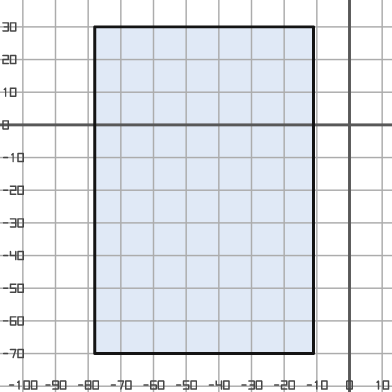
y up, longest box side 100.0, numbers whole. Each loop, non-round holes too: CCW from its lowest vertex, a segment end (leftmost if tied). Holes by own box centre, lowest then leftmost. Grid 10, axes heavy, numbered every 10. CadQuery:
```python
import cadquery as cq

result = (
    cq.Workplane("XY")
    .moveTo(-78.0, -70.0)
    .lineTo(-11.0, -70.0)
    .lineTo(-11.0, 30.0)
    .lineTo(-78.0, 30.0)
    .close()
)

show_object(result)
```